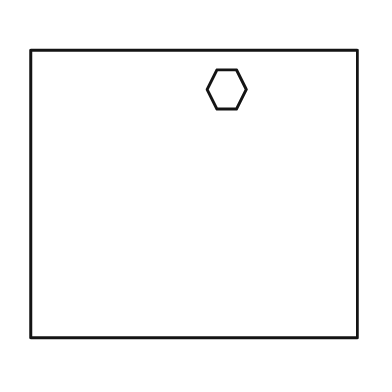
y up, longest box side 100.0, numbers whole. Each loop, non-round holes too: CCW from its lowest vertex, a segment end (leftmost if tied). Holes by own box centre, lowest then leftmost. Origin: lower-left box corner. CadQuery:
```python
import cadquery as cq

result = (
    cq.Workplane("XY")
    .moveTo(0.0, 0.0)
    .lineTo(100.0, 0.0)
    .lineTo(100.0, 88.0)
    .lineTo(0.0, 88.0)
    .close()
    .moveTo(57.0, 70.0)
    .lineTo(63.0, 70.0)
    .lineTo(66.0, 76.0)
    .lineTo(63.0, 82.0)
    .lineTo(57.0, 82.0)
    .lineTo(54.0, 76.0)
    .close()
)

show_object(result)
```